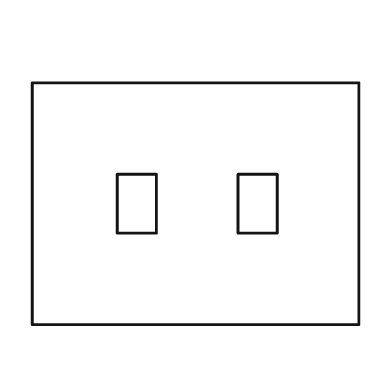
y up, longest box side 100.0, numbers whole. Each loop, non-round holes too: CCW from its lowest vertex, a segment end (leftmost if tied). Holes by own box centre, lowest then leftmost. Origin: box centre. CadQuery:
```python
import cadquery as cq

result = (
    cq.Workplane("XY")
    .moveTo(-50.0, -37.0)
    .lineTo(50.0, -37.0)
    .lineTo(50.0, 37.0)
    .lineTo(-50.0, 37.0)
    .close()
    .moveTo(-24.0, -9.0)
    .lineTo(-12.0, -9.0)
    .lineTo(-12.0, 9.0)
    .lineTo(-24.0, 9.0)
    .close()
    .moveTo(13.0, -9.0)
    .lineTo(25.0, -9.0)
    .lineTo(25.0, 9.0)
    .lineTo(13.0, 9.0)
    .close()
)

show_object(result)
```